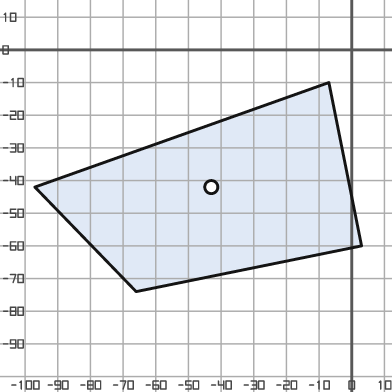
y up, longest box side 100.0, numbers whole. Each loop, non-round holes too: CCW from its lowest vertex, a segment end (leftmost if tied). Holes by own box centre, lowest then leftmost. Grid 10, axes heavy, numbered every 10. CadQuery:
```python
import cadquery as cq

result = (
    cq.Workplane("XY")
    .moveTo(-66.0, -74.0)
    .lineTo(3.0, -60.0)
    .lineTo(-7.0, -10.0)
    .lineTo(-97.0, -42.0)
    .close()
    .moveTo(-43.0, -42.0)
    .circle(2.0)
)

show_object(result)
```